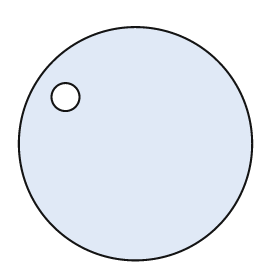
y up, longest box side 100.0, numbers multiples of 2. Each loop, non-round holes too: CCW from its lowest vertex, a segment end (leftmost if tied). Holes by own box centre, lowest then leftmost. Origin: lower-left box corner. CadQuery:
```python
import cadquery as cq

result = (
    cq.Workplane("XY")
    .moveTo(50.0, 50.0)
    .circle(50.0)
    .moveTo(20.0, 70.0)
    .circle(6.0)
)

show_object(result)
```